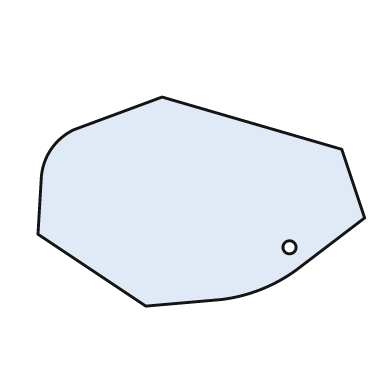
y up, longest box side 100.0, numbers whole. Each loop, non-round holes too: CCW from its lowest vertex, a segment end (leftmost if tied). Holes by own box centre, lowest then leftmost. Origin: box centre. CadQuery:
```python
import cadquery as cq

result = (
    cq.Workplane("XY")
    .moveTo(-17.0, -32.0)
    .lineTo(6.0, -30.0)
    .threePointArc((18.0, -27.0), (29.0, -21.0))
    .lineTo(50.0, -5.0)
    .lineTo(43.0, 16.0)
    .lineTo(-12.0, 32.0)
    .lineTo(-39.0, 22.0)
    .threePointArc((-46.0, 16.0), (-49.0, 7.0))
    .lineTo(-50.0, -10.0)
    .close()
    .moveTo(27.0, -14.0)
    .circle(2.0)
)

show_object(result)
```